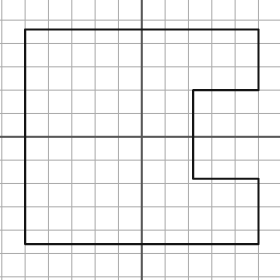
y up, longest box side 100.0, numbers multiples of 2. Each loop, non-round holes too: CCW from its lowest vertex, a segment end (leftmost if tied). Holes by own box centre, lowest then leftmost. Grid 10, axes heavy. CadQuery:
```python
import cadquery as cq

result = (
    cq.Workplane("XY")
    .moveTo(-50.0, -46.0)
    .lineTo(50.0, -46.0)
    .lineTo(50.0, -18.0)
    .lineTo(22.0, -18.0)
    .lineTo(22.0, 20.0)
    .lineTo(50.0, 20.0)
    .lineTo(50.0, 46.0)
    .lineTo(-50.0, 46.0)
    .close()
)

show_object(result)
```